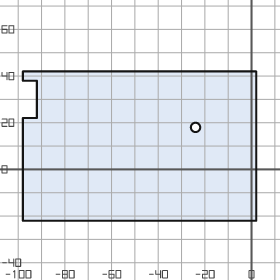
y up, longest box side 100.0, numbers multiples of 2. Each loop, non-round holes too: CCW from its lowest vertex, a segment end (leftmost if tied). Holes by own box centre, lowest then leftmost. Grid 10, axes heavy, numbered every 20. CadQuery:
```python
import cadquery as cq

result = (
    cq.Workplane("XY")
    .moveTo(-98.0, -22.0)
    .lineTo(2.0, -22.0)
    .lineTo(2.0, 42.0)
    .lineTo(-98.0, 42.0)
    .lineTo(-98.0, 38.0)
    .lineTo(-92.0, 38.0)
    .lineTo(-92.0, 22.0)
    .lineTo(-98.0, 22.0)
    .close()
    .moveTo(-24.0, 18.0)
    .circle(2.0)
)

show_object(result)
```